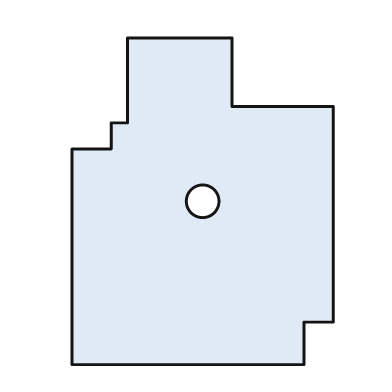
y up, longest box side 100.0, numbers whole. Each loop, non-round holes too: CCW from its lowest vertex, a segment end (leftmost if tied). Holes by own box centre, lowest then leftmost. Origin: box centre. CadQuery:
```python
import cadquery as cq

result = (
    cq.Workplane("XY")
    .moveTo(-40.0, -50.0)
    .lineTo(31.0, -50.0)
    .lineTo(31.0, -37.0)
    .lineTo(40.0, -37.0)
    .lineTo(40.0, 29.0)
    .lineTo(9.0, 29.0)
    .lineTo(9.0, 50.0)
    .lineTo(-23.0, 50.0)
    .lineTo(-23.0, 24.0)
    .lineTo(-28.0, 24.0)
    .lineTo(-28.0, 16.0)
    .lineTo(-40.0, 16.0)
    .close()
    .moveTo(0.0, 0.0)
    .circle(5.0)
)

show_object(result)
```